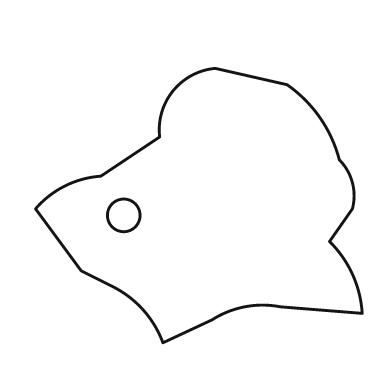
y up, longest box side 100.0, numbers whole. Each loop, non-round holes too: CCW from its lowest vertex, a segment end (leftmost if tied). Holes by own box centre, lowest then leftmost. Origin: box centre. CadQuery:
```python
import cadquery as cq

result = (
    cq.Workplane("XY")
    .moveTo(-11.0, -42.0)
    .lineTo(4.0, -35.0)
    .threePointArc((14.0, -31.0), (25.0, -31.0))
    .lineTo(50.0, -33.0)
    .threePointArc((47.0, -21.0), (40.0, -11.0))
    .lineTo(47.0, -1.0)
    .threePointArc((47.0, 7.0), (43.0, 14.0))
    .threePointArc((37.0, 27.0), (27.0, 37.0))
    .lineTo(5.0, 42.0)
    .threePointArc((-8.0, 35.0), (-12.0, 21.0))
    .lineTo(-30.0, 9.0)
    .threePointArc((-41.0, 6.0), (-50.0, -1.0))
    .lineTo(-36.0, -20.0)
    .lineTo(-26.0, -25.0)
    .threePointArc((-17.0, -32.0), (-11.0, -42.0))
    .close()
    .moveTo(-23.0, -3.0)
    .circle(5.0)
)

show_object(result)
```